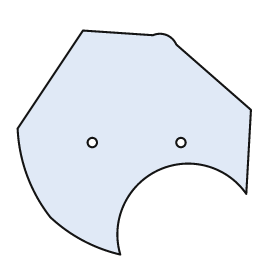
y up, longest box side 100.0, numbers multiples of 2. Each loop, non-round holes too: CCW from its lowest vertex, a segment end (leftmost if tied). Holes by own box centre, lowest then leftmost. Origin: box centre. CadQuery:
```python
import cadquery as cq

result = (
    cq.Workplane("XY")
    .moveTo(-6.0, -48.0)
    .threePointArc((10.0, -12.0), (48.0, -22.0))
    .lineTo(50.0, 14.0)
    .lineTo(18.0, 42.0)
    .threePointArc((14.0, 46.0), (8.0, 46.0))
    .lineTo(-22.0, 48.0)
    .lineTo(-50.0, 6.0)
    .threePointArc((-46.0, -14.0), (-36.0, -32.0))
    .threePointArc((-22.0, -42.0), (-6.0, -48.0))
    .close()
    .moveTo(-18.0, 0.0)
    .circle(2.0)
    .moveTo(20.0, 0.0)
    .circle(2.0)
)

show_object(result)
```